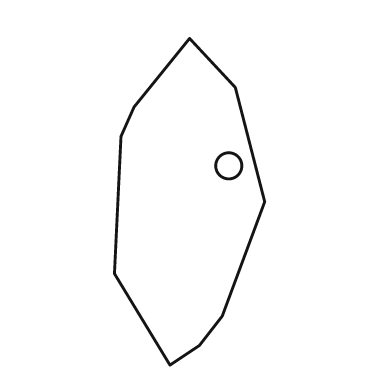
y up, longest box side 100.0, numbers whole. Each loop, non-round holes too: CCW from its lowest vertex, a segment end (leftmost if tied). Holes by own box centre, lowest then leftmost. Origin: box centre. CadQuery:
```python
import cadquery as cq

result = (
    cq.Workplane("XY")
    .moveTo(-6.0, -50.0)
    .lineTo(3.0, -44.0)
    .lineTo(10.0, -35.0)
    .lineTo(23.0, 0.0)
    .lineTo(14.0, 35.0)
    .lineTo(0.0, 50.0)
    .lineTo(-17.0, 29.0)
    .lineTo(-21.0, 20.0)
    .lineTo(-23.0, -22.0)
    .close()
    .moveTo(12.0, 11.0)
    .circle(4.0)
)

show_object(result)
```